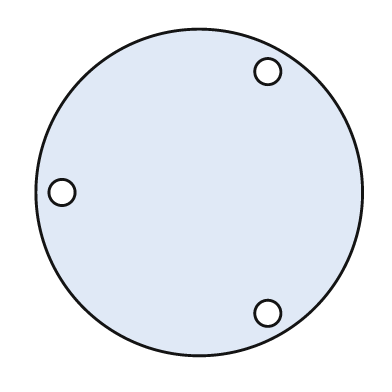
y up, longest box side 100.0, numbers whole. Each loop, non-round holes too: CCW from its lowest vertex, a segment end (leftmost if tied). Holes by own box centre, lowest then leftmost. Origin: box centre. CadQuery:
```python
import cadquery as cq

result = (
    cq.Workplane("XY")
    .moveTo(0.0, 0.0)
    .circle(50.0)
    .moveTo(21.0, -37.0)
    .circle(4.0)
    .moveTo(-42.0, 0.0)
    .circle(4.0)
    .moveTo(21.0, 37.0)
    .circle(4.0)
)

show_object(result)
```